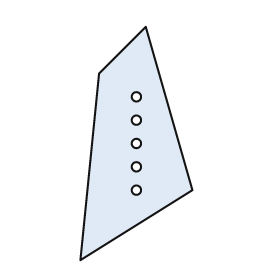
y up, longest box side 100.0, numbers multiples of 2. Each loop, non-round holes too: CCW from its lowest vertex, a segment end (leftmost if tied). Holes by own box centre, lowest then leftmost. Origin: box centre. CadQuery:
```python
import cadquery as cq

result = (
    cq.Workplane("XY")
    .moveTo(-24.0, -50.0)
    .lineTo(24.0, -20.0)
    .lineTo(4.0, 50.0)
    .lineTo(-16.0, 30.0)
    .close()
    .moveTo(0.0, -20.0)
    .circle(2.0)
    .moveTo(0.0, -10.0)
    .circle(2.0)
    .moveTo(0.0, 0.0)
    .circle(2.0)
    .moveTo(0.0, 10.0)
    .circle(2.0)
    .moveTo(0.0, 20.0)
    .circle(2.0)
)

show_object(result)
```